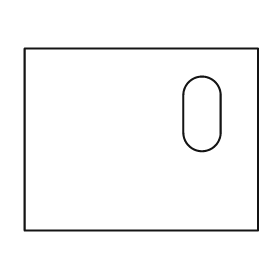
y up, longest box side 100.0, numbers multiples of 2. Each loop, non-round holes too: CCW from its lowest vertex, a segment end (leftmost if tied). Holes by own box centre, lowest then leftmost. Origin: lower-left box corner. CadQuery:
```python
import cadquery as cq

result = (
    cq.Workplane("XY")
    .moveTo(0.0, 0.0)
    .lineTo(100.0, 0.0)
    .lineTo(100.0, 78.0)
    .lineTo(0.0, 78.0)
    .close()
    .moveTo(68.0, 42.0)
    .threePointArc((76.0, 34.0), (84.0, 42.0))
    .lineTo(84.0, 58.0)
    .threePointArc((76.0, 66.0), (68.0, 58.0))
    .close()
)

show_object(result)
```